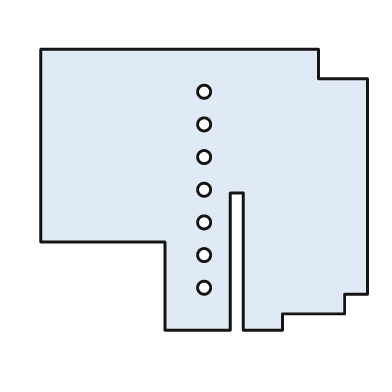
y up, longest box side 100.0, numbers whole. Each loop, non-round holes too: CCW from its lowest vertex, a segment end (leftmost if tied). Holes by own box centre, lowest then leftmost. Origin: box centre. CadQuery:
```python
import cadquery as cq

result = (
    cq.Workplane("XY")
    .moveTo(-12.0, -43.0)
    .lineTo(8.0, -43.0)
    .lineTo(8.0, -1.0)
    .lineTo(12.0, -1.0)
    .lineTo(12.0, -43.0)
    .lineTo(24.0, -43.0)
    .lineTo(24.0, -38.0)
    .lineTo(43.0, -38.0)
    .lineTo(43.0, -32.0)
    .lineTo(50.0, -32.0)
    .lineTo(50.0, 34.0)
    .lineTo(35.0, 34.0)
    .lineTo(35.0, 43.0)
    .lineTo(-50.0, 43.0)
    .lineTo(-50.0, -16.0)
    .lineTo(-12.0, -16.0)
    .close()
    .moveTo(0.0, -30.0)
    .circle(2.0)
    .moveTo(0.0, -20.0)
    .circle(2.0)
    .moveTo(0.0, -10.0)
    .circle(2.0)
    .moveTo(0.0, 0.0)
    .circle(2.0)
    .moveTo(0.0, 10.0)
    .circle(2.0)
    .moveTo(0.0, 20.0)
    .circle(2.0)
    .moveTo(0.0, 30.0)
    .circle(2.0)
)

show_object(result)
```